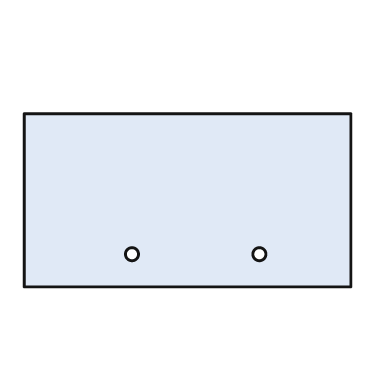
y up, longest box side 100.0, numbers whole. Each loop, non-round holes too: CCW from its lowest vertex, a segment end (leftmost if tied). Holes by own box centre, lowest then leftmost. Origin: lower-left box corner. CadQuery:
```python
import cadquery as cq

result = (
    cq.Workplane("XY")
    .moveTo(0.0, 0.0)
    .lineTo(100.0, 0.0)
    .lineTo(100.0, 53.0)
    .lineTo(0.0, 53.0)
    .close()
    .moveTo(33.0, 10.0)
    .circle(2.0)
    .moveTo(72.0, 10.0)
    .circle(2.0)
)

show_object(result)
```